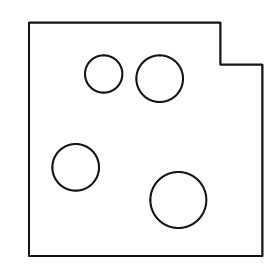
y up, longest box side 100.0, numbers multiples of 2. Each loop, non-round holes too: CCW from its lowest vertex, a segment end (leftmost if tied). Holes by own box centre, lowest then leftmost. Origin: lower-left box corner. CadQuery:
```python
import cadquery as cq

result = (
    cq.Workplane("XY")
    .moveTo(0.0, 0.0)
    .lineTo(100.0, 0.0)
    .lineTo(100.0, 82.0)
    .lineTo(82.0, 82.0)
    .lineTo(82.0, 100.0)
    .lineTo(0.0, 100.0)
    .close()
    .moveTo(64.0, 24.0)
    .circle(12.0)
    .moveTo(20.0, 38.0)
    .circle(10.0)
    .moveTo(56.0, 76.0)
    .circle(10.0)
    .moveTo(32.0, 78.0)
    .circle(8.0)
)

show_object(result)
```